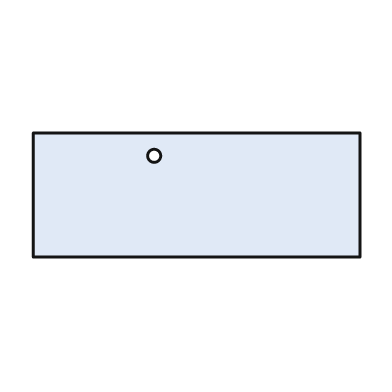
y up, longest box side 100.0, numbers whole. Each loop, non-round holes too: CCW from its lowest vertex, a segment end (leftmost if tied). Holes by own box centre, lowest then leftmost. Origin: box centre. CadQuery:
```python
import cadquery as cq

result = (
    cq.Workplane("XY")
    .moveTo(-50.0, -19.0)
    .lineTo(50.0, -19.0)
    .lineTo(50.0, 19.0)
    .lineTo(-50.0, 19.0)
    .close()
    .moveTo(-13.0, 12.0)
    .circle(2.0)
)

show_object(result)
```